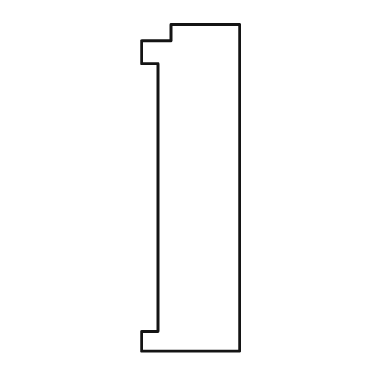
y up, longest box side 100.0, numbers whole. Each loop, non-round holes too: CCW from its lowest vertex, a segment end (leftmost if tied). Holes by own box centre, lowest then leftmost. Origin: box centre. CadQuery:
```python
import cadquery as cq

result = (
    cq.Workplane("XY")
    .moveTo(-15.0, -50.0)
    .lineTo(15.0, -50.0)
    .lineTo(15.0, 50.0)
    .lineTo(-6.0, 50.0)
    .lineTo(-6.0, 45.0)
    .lineTo(-15.0, 45.0)
    .lineTo(-15.0, 38.0)
    .lineTo(-10.0, 38.0)
    .lineTo(-10.0, -44.0)
    .lineTo(-15.0, -44.0)
    .close()
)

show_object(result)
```